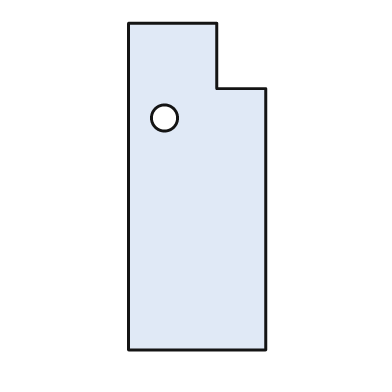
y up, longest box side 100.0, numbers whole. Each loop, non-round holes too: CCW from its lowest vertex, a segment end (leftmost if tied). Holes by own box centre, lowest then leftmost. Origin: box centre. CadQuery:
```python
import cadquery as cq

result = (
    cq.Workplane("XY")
    .moveTo(-21.0, -50.0)
    .lineTo(21.0, -50.0)
    .lineTo(21.0, 30.0)
    .lineTo(6.0, 30.0)
    .lineTo(6.0, 50.0)
    .lineTo(-21.0, 50.0)
    .close()
    .moveTo(-10.0, 21.0)
    .circle(4.0)
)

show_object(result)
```